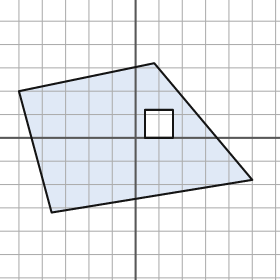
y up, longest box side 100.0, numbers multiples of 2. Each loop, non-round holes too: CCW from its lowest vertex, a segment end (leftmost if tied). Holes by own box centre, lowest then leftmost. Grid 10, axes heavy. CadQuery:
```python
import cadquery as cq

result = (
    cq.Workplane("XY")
    .moveTo(-36.0, -32.0)
    .lineTo(50.0, -18.0)
    .lineTo(8.0, 32.0)
    .lineTo(-50.0, 20.0)
    .close()
    .moveTo(4.0, 0.0)
    .lineTo(16.0, 0.0)
    .lineTo(16.0, 12.0)
    .lineTo(4.0, 12.0)
    .close()
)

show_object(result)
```